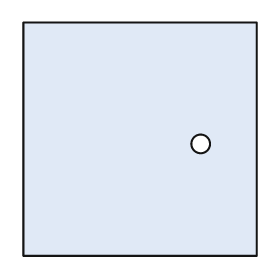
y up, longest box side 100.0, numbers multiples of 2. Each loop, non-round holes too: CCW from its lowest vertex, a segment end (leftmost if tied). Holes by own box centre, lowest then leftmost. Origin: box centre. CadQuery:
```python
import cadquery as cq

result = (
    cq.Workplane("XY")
    .moveTo(-50.0, -50.0)
    .lineTo(50.0, -50.0)
    .lineTo(50.0, 50.0)
    .lineTo(-50.0, 50.0)
    .close()
    .moveTo(26.0, -2.0)
    .circle(4.0)
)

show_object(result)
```